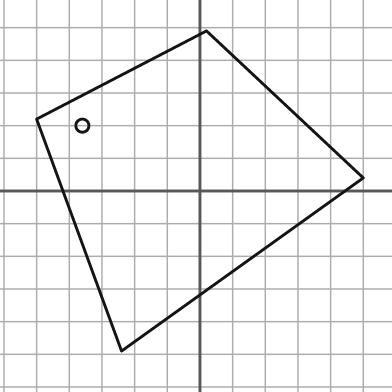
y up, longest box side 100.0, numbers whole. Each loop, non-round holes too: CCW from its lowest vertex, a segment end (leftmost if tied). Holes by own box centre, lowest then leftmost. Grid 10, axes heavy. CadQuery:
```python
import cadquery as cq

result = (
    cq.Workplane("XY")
    .moveTo(-24.0, -49.0)
    .lineTo(50.0, 4.0)
    .lineTo(2.0, 49.0)
    .lineTo(-50.0, 22.0)
    .close()
    .moveTo(-36.0, 20.0)
    .circle(2.0)
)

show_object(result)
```